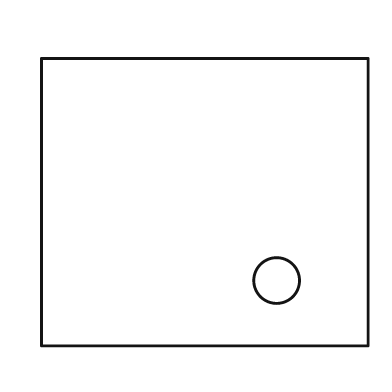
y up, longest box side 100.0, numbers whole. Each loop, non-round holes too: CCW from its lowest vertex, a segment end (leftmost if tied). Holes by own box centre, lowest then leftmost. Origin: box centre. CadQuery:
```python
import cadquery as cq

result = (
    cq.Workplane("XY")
    .moveTo(-50.0, -44.0)
    .lineTo(50.0, -44.0)
    .lineTo(50.0, 44.0)
    .lineTo(-50.0, 44.0)
    .close()
    .moveTo(22.0, -24.0)
    .circle(7.0)
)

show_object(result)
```